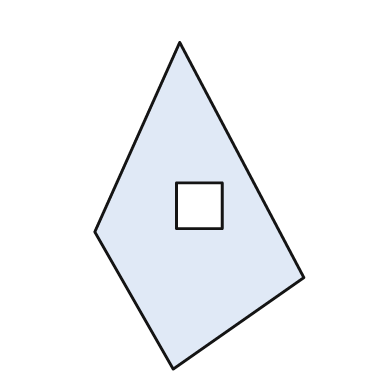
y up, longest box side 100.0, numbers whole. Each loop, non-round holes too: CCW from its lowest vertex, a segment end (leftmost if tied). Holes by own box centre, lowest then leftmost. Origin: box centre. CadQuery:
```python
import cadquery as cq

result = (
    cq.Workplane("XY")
    .moveTo(-8.0, -50.0)
    .lineTo(32.0, -22.0)
    .lineTo(-6.0, 50.0)
    .lineTo(-32.0, -8.0)
    .close()
    .moveTo(-7.0, -7.0)
    .lineTo(7.0, -7.0)
    .lineTo(7.0, 7.0)
    .lineTo(-7.0, 7.0)
    .close()
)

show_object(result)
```